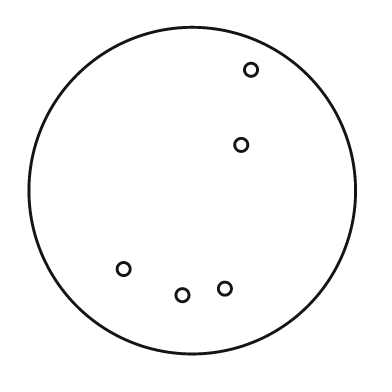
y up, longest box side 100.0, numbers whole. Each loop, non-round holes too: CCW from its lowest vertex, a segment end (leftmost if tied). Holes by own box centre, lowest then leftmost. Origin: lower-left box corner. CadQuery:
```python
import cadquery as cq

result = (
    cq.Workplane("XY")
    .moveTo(50.0, 50.0)
    .circle(50.0)
    .moveTo(47.0, 18.0)
    .circle(2.0)
    .moveTo(60.0, 20.0)
    .circle(2.0)
    .moveTo(29.0, 26.0)
    .circle(2.0)
    .moveTo(65.0, 64.0)
    .circle(2.0)
    .moveTo(68.0, 87.0)
    .circle(2.0)
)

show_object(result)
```